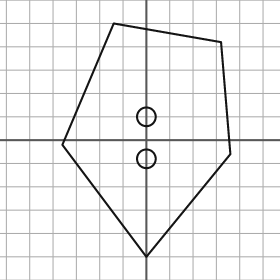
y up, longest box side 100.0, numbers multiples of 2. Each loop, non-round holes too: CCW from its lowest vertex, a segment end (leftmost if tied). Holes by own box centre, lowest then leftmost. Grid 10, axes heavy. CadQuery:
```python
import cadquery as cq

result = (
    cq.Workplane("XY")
    .moveTo(0.0, -50.0)
    .lineTo(36.0, -6.0)
    .lineTo(32.0, 42.0)
    .lineTo(-14.0, 50.0)
    .lineTo(-36.0, -2.0)
    .close()
    .moveTo(0.0, -8.0)
    .circle(4.0)
    .moveTo(0.0, 10.0)
    .circle(4.0)
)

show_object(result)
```